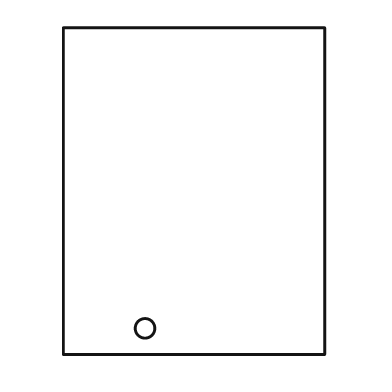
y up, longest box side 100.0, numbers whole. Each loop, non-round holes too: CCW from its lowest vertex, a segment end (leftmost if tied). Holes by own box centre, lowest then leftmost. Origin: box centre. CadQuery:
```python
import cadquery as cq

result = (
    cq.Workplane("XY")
    .moveTo(-40.0, -50.0)
    .lineTo(40.0, -50.0)
    .lineTo(40.0, 50.0)
    .lineTo(-40.0, 50.0)
    .close()
    .moveTo(-15.0, -42.0)
    .circle(3.0)
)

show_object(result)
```